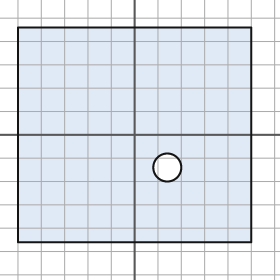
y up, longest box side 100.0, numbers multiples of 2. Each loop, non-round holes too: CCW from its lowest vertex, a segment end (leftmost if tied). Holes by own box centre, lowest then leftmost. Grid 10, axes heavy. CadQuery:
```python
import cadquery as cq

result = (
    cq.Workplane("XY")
    .moveTo(-50.0, -46.0)
    .lineTo(50.0, -46.0)
    .lineTo(50.0, 46.0)
    .lineTo(-50.0, 46.0)
    .close()
    .moveTo(14.0, -14.0)
    .circle(6.0)
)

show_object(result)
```